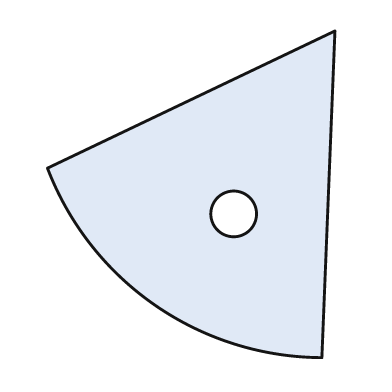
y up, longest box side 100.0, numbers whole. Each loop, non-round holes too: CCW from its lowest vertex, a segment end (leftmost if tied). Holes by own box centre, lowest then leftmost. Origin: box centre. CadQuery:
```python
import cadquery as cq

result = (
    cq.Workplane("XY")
    .moveTo(40.0, -50.0)
    .lineTo(44.0, 50.0)
    .lineTo(-44.0, 8.0)
    .threePointArc((-11.0, -34.0), (40.0, -50.0))
    .close()
    .moveTo(13.0, -6.0)
    .circle(7.0)
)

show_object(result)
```